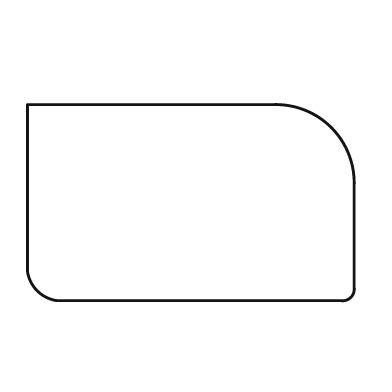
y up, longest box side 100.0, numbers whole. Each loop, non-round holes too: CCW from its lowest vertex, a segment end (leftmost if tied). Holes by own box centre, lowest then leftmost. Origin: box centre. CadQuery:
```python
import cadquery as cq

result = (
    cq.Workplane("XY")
    .moveTo(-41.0, -30.0)
    .lineTo(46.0, -30.0)
    .threePointArc((49.0, -29.0), (50.0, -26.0))
    .lineTo(50.0, 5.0)
    .threePointArc((43.0, 23.0), (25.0, 30.0))
    .lineTo(-50.0, 30.0)
    .lineTo(-50.0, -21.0)
    .threePointArc((-47.0, -27.0), (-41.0, -30.0))
    .close()
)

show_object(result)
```